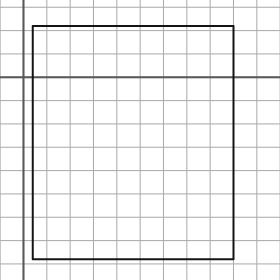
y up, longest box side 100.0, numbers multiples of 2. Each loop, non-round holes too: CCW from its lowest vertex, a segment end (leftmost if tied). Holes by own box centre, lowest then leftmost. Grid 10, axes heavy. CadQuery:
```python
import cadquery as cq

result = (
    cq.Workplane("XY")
    .moveTo(4.0, -78.0)
    .lineTo(90.0, -78.0)
    .lineTo(90.0, 22.0)
    .lineTo(4.0, 22.0)
    .close()
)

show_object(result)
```